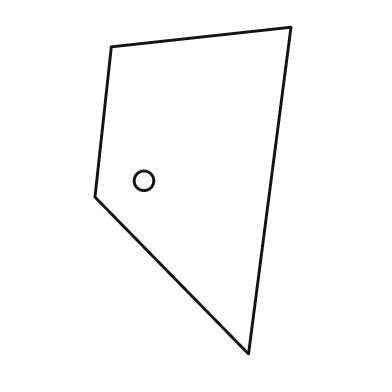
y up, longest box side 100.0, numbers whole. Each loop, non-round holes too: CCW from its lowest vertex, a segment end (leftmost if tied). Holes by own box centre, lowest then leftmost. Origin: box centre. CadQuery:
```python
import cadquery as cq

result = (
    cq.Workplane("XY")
    .moveTo(17.0, -50.0)
    .lineTo(30.0, 50.0)
    .lineTo(-25.0, 44.0)
    .lineTo(-30.0, -2.0)
    .close()
    .moveTo(-15.0, 3.0)
    .circle(3.0)
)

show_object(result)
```